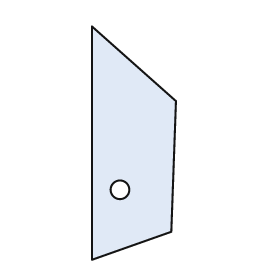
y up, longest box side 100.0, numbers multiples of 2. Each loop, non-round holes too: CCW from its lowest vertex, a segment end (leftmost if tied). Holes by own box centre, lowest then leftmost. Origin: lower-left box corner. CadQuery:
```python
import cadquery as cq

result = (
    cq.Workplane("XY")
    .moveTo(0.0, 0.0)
    .lineTo(34.0, 12.0)
    .lineTo(36.0, 68.0)
    .lineTo(0.0, 100.0)
    .close()
    .moveTo(12.0, 30.0)
    .circle(4.0)
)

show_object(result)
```